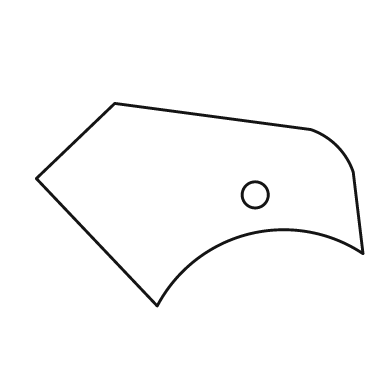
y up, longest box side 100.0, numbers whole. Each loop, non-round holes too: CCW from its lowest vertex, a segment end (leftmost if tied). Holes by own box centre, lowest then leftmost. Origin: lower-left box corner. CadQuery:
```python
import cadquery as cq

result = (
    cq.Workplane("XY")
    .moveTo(37.0, 0.0)
    .threePointArc((65.0, 22.0), (100.0, 16.0))
    .lineTo(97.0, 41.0)
    .threePointArc((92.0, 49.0), (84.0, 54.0))
    .lineTo(24.0, 62.0)
    .lineTo(0.0, 39.0)
    .close()
    .moveTo(67.0, 34.0)
    .circle(4.0)
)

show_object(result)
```